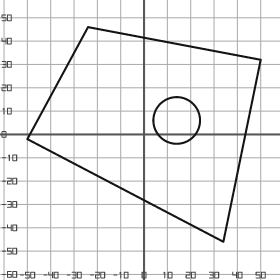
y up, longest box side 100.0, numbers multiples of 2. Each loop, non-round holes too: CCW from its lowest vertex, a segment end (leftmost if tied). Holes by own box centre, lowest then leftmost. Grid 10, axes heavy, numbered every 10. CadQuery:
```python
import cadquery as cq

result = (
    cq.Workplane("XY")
    .moveTo(34.0, -46.0)
    .lineTo(50.0, 32.0)
    .lineTo(-24.0, 46.0)
    .lineTo(-50.0, -2.0)
    .close()
    .moveTo(14.0, 6.0)
    .circle(10.0)
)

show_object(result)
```